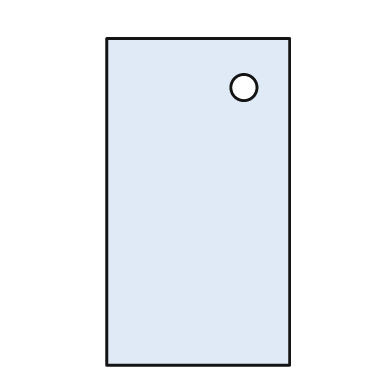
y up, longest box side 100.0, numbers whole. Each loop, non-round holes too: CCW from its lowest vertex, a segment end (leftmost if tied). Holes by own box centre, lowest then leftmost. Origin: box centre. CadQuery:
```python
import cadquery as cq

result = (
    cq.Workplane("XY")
    .moveTo(-28.0, -50.0)
    .lineTo(28.0, -50.0)
    .lineTo(28.0, 50.0)
    .lineTo(-28.0, 50.0)
    .close()
    .moveTo(14.0, 35.0)
    .circle(4.0)
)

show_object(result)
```